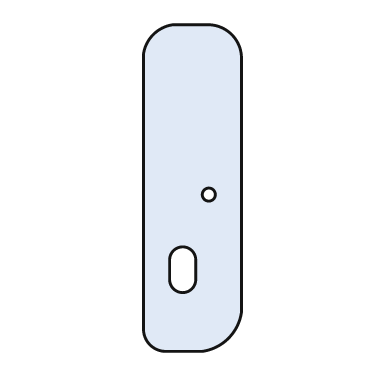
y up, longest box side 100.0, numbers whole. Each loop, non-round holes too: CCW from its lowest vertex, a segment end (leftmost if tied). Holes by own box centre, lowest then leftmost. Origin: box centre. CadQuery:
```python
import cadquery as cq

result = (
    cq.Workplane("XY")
    .moveTo(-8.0, -50.0)
    .lineTo(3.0, -50.0)
    .threePointArc((11.0, -46.0), (15.0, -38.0))
    .lineTo(15.0, 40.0)
    .threePointArc((12.0, 47.0), (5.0, 50.0))
    .lineTo(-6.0, 50.0)
    .threePointArc((-12.0, 47.0), (-15.0, 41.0))
    .lineTo(-15.0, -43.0)
    .threePointArc((-13.0, -48.0), (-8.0, -50.0))
    .close()
    .moveTo(-7.0, -28.0)
    .threePointArc((-3.0, -32.0), (1.0, -28.0))
    .lineTo(1.0, -22.0)
    .threePointArc((-3.0, -18.0), (-7.0, -22.0))
    .close()
    .moveTo(5.0, -2.0)
    .circle(2.0)
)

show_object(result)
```